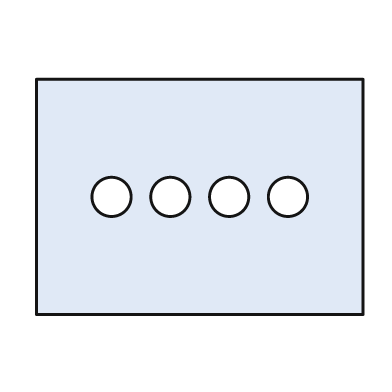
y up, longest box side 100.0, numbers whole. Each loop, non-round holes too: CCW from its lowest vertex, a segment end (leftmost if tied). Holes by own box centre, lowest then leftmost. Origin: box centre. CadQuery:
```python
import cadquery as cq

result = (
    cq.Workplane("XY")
    .moveTo(-50.0, -36.0)
    .lineTo(50.0, -36.0)
    .lineTo(50.0, 36.0)
    .lineTo(-50.0, 36.0)
    .close()
    .moveTo(-27.0, 0.0)
    .circle(6.0)
    .moveTo(-9.0, 0.0)
    .circle(6.0)
    .moveTo(9.0, 0.0)
    .circle(6.0)
    .moveTo(27.0, 0.0)
    .circle(6.0)
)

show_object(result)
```